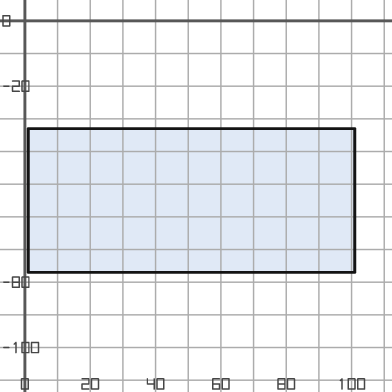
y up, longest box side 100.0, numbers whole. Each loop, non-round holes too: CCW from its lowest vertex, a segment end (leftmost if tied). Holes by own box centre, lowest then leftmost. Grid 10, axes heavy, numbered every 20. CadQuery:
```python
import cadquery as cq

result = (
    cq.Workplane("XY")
    .moveTo(1.0, -77.0)
    .lineTo(101.0, -77.0)
    .lineTo(101.0, -33.0)
    .lineTo(1.0, -33.0)
    .close()
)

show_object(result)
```